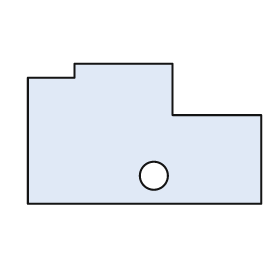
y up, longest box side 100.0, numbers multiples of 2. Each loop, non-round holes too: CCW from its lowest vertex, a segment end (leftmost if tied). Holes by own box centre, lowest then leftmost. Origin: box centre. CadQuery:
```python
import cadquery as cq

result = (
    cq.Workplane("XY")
    .moveTo(-50.0, -30.0)
    .lineTo(50.0, -30.0)
    .lineTo(50.0, 8.0)
    .lineTo(12.0, 8.0)
    .lineTo(12.0, 30.0)
    .lineTo(-30.0, 30.0)
    .lineTo(-30.0, 24.0)
    .lineTo(-50.0, 24.0)
    .close()
    .moveTo(4.0, -18.0)
    .circle(6.0)
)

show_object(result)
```